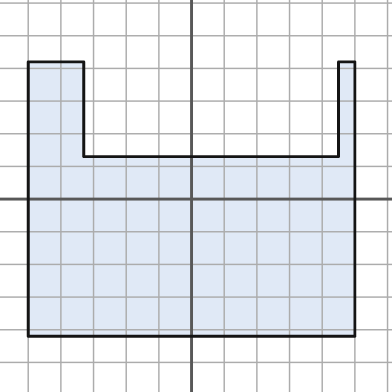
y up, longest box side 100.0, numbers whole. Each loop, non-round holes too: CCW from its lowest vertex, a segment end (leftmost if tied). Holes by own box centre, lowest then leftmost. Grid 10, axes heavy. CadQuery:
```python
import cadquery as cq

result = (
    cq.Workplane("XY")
    .moveTo(-50.0, -42.0)
    .lineTo(50.0, -42.0)
    .lineTo(50.0, 42.0)
    .lineTo(45.0, 42.0)
    .lineTo(45.0, 13.0)
    .lineTo(-33.0, 13.0)
    .lineTo(-33.0, 42.0)
    .lineTo(-50.0, 42.0)
    .close()
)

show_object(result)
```